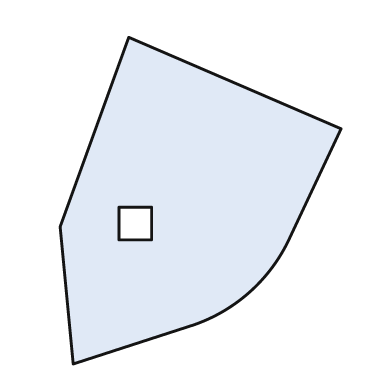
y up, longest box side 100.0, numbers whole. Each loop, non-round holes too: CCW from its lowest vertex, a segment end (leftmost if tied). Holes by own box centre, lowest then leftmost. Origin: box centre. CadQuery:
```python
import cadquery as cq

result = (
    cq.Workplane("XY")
    .moveTo(-39.0, -50.0)
    .lineTo(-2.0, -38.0)
    .threePointArc((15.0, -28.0), (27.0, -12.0))
    .lineTo(43.0, 22.0)
    .lineTo(-22.0, 50.0)
    .lineTo(-43.0, -8.0)
    .close()
    .moveTo(-25.0, -12.0)
    .lineTo(-15.0, -12.0)
    .lineTo(-15.0, -2.0)
    .lineTo(-25.0, -2.0)
    .close()
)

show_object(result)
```